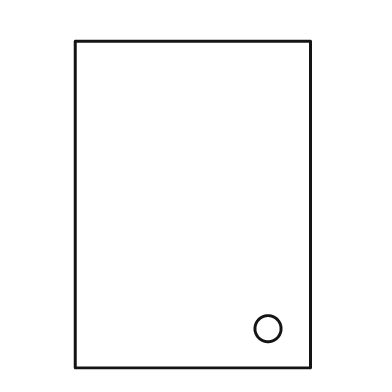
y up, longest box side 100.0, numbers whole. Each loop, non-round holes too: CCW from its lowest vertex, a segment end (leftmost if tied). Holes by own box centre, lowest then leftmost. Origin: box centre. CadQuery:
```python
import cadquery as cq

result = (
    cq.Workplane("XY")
    .moveTo(-36.0, -50.0)
    .lineTo(36.0, -50.0)
    .lineTo(36.0, 50.0)
    .lineTo(-36.0, 50.0)
    .close()
    .moveTo(23.0, -38.0)
    .circle(4.0)
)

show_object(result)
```